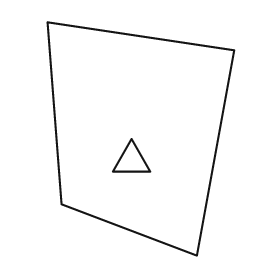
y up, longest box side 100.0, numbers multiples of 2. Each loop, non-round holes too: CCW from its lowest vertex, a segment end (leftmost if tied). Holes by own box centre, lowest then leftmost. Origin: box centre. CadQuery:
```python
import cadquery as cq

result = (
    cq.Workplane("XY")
    .moveTo(24.0, -50.0)
    .lineTo(40.0, 38.0)
    .lineTo(-40.0, 50.0)
    .lineTo(-34.0, -28.0)
    .close()
    .moveTo(-12.0, -14.0)
    .lineTo(4.0, -14.0)
    .lineTo(-4.0, 0.0)
    .close()
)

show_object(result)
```